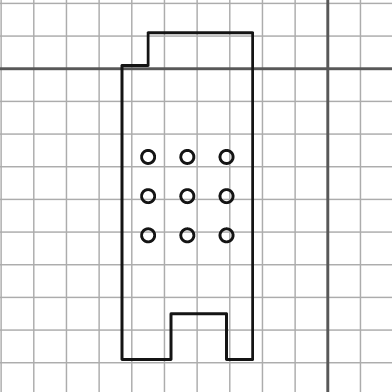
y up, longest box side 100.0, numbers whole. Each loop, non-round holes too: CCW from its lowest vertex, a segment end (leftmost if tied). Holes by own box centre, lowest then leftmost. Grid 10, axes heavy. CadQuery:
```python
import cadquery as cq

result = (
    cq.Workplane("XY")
    .moveTo(-63.0, -89.0)
    .lineTo(-48.0, -89.0)
    .lineTo(-48.0, -75.0)
    .lineTo(-31.0, -75.0)
    .lineTo(-31.0, -89.0)
    .lineTo(-23.0, -89.0)
    .lineTo(-23.0, 11.0)
    .lineTo(-55.0, 11.0)
    .lineTo(-55.0, 1.0)
    .lineTo(-63.0, 1.0)
    .close()
    .moveTo(-55.0, -51.0)
    .circle(2.0)
    .moveTo(-43.0, -51.0)
    .circle(2.0)
    .moveTo(-31.0, -51.0)
    .circle(2.0)
    .moveTo(-55.0, -39.0)
    .circle(2.0)
    .moveTo(-43.0, -39.0)
    .circle(2.0)
    .moveTo(-31.0, -39.0)
    .circle(2.0)
    .moveTo(-55.0, -27.0)
    .circle(2.0)
    .moveTo(-43.0, -27.0)
    .circle(2.0)
    .moveTo(-31.0, -27.0)
    .circle(2.0)
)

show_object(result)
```